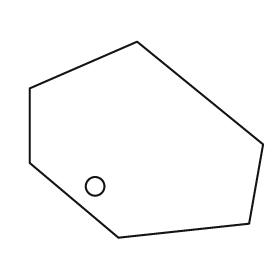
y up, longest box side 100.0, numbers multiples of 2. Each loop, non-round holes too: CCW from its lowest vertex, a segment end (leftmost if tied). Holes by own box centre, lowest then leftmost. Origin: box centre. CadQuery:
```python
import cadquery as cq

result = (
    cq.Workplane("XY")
    .moveTo(-12.0, -42.0)
    .lineTo(44.0, -36.0)
    .lineTo(50.0, -2.0)
    .lineTo(-4.0, 42.0)
    .lineTo(-50.0, 22.0)
    .lineTo(-50.0, -10.0)
    .close()
    .moveTo(-22.0, -20.0)
    .circle(4.0)
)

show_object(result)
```